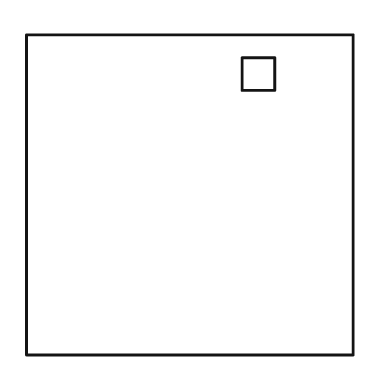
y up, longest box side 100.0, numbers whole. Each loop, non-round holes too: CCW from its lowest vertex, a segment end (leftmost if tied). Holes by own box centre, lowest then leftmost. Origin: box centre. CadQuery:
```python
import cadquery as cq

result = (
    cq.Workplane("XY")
    .moveTo(-50.0, -49.0)
    .lineTo(50.0, -49.0)
    .lineTo(50.0, 49.0)
    .lineTo(-50.0, 49.0)
    .close()
    .moveTo(16.0, 32.0)
    .lineTo(26.0, 32.0)
    .lineTo(26.0, 42.0)
    .lineTo(16.0, 42.0)
    .close()
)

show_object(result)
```